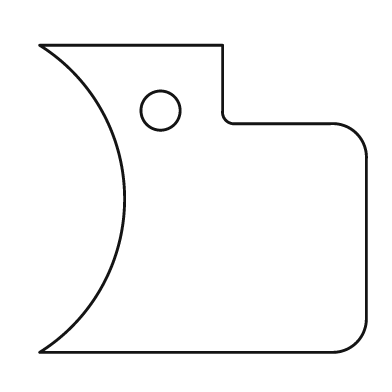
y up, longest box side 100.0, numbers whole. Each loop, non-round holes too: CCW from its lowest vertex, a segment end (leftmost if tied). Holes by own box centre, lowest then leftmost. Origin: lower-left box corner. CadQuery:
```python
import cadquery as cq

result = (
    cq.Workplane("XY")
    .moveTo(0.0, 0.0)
    .lineTo(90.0, 0.0)
    .threePointArc((97.0, 3.0), (100.0, 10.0))
    .lineTo(100.0, 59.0)
    .threePointArc((97.0, 67.0), (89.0, 70.0))
    .lineTo(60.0, 70.0)
    .threePointArc((57.0, 71.0), (56.0, 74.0))
    .lineTo(56.0, 94.0)
    .lineTo(0.0, 94.0)
    .threePointArc((26.0, 47.0), (0.0, 0.0))
    .close()
    .moveTo(37.0, 74.0)
    .circle(6.0)
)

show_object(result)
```